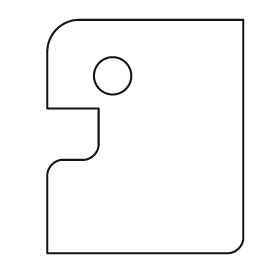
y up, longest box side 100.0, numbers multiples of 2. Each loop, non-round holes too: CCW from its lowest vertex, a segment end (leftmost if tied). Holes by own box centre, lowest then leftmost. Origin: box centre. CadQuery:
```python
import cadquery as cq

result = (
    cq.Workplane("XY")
    .moveTo(-42.0, -50.0)
    .lineTo(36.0, -50.0)
    .threePointArc((40.0, -48.0), (42.0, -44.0))
    .lineTo(42.0, 50.0)
    .lineTo(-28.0, 50.0)
    .threePointArc((-38.0, 46.0), (-42.0, 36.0))
    .lineTo(-42.0, 12.0)
    .lineTo(-20.0, 12.0)
    .lineTo(-20.0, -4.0)
    .threePointArc((-22.0, -8.0), (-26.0, -10.0))
    .lineTo(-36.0, -10.0)
    .threePointArc((-40.0, -12.0), (-42.0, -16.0))
    .close()
    .moveTo(-14.0, 26.0)
    .circle(8.0)
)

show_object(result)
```